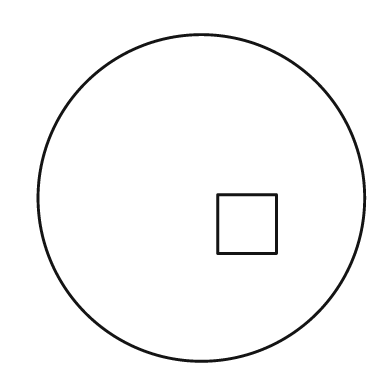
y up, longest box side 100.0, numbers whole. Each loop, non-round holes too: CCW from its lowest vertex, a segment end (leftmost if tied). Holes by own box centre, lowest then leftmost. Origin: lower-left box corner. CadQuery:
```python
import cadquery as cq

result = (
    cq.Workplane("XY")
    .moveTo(50.0, 50.0)
    .circle(50.0)
    .moveTo(55.0, 33.0)
    .lineTo(73.0, 33.0)
    .lineTo(73.0, 51.0)
    .lineTo(55.0, 51.0)
    .close()
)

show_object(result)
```